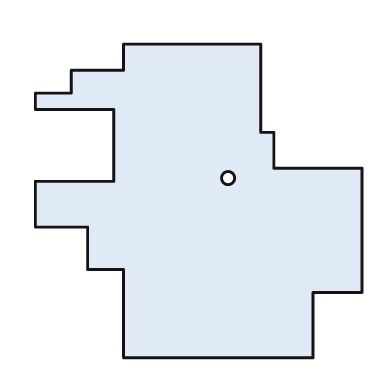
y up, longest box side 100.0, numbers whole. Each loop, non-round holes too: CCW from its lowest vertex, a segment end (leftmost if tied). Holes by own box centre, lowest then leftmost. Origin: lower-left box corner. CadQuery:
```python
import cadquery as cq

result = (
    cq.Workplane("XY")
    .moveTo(27.0, 0.0)
    .lineTo(85.0, 0.0)
    .lineTo(85.0, 20.0)
    .lineTo(100.0, 20.0)
    .lineTo(100.0, 58.0)
    .lineTo(73.0, 58.0)
    .lineTo(73.0, 69.0)
    .lineTo(69.0, 69.0)
    .lineTo(69.0, 96.0)
    .lineTo(27.0, 96.0)
    .lineTo(27.0, 88.0)
    .lineTo(11.0, 88.0)
    .lineTo(11.0, 81.0)
    .lineTo(0.0, 81.0)
    .lineTo(0.0, 76.0)
    .lineTo(24.0, 76.0)
    .lineTo(24.0, 54.0)
    .lineTo(0.0, 54.0)
    .lineTo(0.0, 40.0)
    .lineTo(16.0, 40.0)
    .lineTo(16.0, 27.0)
    .lineTo(27.0, 27.0)
    .close()
    .moveTo(59.0, 55.0)
    .circle(2.0)
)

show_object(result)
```